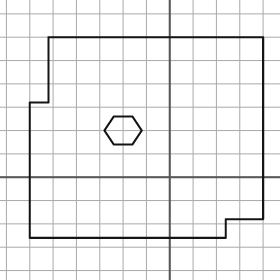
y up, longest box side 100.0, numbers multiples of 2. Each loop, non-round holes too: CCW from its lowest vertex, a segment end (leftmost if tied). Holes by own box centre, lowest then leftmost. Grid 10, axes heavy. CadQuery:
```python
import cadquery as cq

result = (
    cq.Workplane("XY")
    .moveTo(-60.0, -26.0)
    .lineTo(24.0, -26.0)
    .lineTo(24.0, -18.0)
    .lineTo(40.0, -18.0)
    .lineTo(40.0, 60.0)
    .lineTo(-52.0, 60.0)
    .lineTo(-52.0, 32.0)
    .lineTo(-60.0, 32.0)
    .close()
    .moveTo(-24.0, 14.0)
    .lineTo(-16.0, 14.0)
    .lineTo(-12.0, 20.0)
    .lineTo(-16.0, 26.0)
    .lineTo(-24.0, 26.0)
    .lineTo(-28.0, 20.0)
    .close()
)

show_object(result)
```